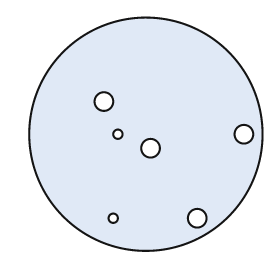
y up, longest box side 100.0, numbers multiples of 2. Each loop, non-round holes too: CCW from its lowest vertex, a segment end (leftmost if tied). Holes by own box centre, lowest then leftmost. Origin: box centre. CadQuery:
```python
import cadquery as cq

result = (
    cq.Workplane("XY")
    .moveTo(0.0, 0.0)
    .circle(50.0)
    .moveTo(-14.0, -36.0)
    .circle(2.0)
    .moveTo(22.0, -36.0)
    .circle(4.0)
    .moveTo(2.0, -6.0)
    .circle(4.0)
    .moveTo(-12.0, 0.0)
    .circle(2.0)
    .moveTo(42.0, 0.0)
    .circle(4.0)
    .moveTo(-18.0, 14.0)
    .circle(4.0)
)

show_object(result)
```